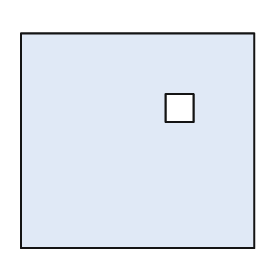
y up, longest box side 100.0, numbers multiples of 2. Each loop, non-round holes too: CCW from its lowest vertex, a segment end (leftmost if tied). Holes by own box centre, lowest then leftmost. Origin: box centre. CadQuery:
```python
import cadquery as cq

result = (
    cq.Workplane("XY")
    .moveTo(-50.0, -46.0)
    .lineTo(50.0, -46.0)
    .lineTo(50.0, 46.0)
    .lineTo(-50.0, 46.0)
    .close()
    .moveTo(12.0, 8.0)
    .lineTo(24.0, 8.0)
    .lineTo(24.0, 20.0)
    .lineTo(12.0, 20.0)
    .close()
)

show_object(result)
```